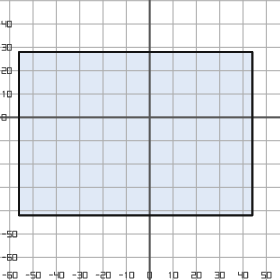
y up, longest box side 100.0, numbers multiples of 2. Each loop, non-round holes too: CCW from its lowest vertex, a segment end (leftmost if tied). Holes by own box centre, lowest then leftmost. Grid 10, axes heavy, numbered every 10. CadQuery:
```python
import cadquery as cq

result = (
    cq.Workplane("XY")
    .moveTo(-56.0, -42.0)
    .lineTo(44.0, -42.0)
    .lineTo(44.0, 28.0)
    .lineTo(-56.0, 28.0)
    .close()
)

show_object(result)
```